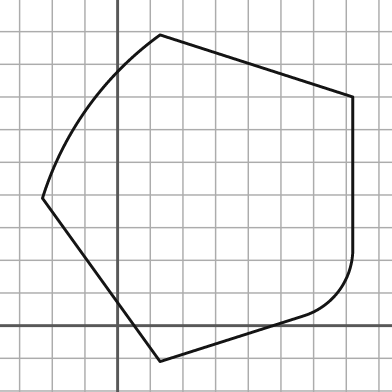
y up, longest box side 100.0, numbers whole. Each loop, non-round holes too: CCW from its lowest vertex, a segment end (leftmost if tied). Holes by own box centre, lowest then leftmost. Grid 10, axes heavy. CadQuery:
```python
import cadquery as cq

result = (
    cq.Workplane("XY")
    .moveTo(13.0, -11.0)
    .lineTo(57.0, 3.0)
    .threePointArc((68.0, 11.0), (72.0, 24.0))
    .lineTo(72.0, 70.0)
    .lineTo(13.0, 89.0)
    .threePointArc((-9.0, 67.0), (-23.0, 39.0))
    .close()
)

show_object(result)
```